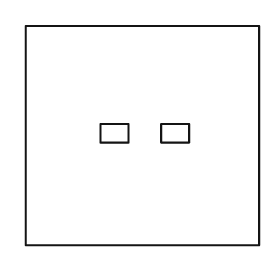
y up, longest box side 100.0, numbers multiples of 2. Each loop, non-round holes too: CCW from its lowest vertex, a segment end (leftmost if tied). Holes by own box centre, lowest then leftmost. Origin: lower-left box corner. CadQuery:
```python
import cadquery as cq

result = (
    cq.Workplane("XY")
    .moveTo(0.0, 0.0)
    .lineTo(100.0, 0.0)
    .lineTo(100.0, 94.0)
    .lineTo(0.0, 94.0)
    .close()
    .moveTo(32.0, 44.0)
    .lineTo(44.0, 44.0)
    .lineTo(44.0, 52.0)
    .lineTo(32.0, 52.0)
    .close()
    .moveTo(58.0, 44.0)
    .lineTo(70.0, 44.0)
    .lineTo(70.0, 52.0)
    .lineTo(58.0, 52.0)
    .close()
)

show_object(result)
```